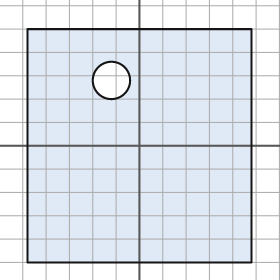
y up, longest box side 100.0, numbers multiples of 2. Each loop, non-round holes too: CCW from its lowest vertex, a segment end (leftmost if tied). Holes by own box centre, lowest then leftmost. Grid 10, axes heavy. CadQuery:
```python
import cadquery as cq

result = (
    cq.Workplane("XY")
    .moveTo(-48.0, -50.0)
    .lineTo(48.0, -50.0)
    .lineTo(48.0, 50.0)
    .lineTo(-48.0, 50.0)
    .close()
    .moveTo(-12.0, 28.0)
    .circle(8.0)
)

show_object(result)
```